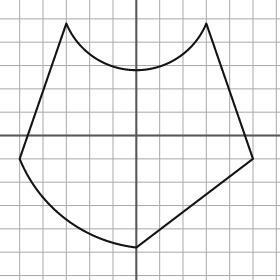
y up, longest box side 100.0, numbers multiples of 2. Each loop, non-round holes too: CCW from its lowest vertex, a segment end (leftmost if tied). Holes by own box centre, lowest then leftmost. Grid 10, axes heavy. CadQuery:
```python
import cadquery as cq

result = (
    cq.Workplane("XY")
    .moveTo(0.0, -48.0)
    .lineTo(50.0, -10.0)
    .lineTo(30.0, 48.0)
    .threePointArc((0.0, 28.0), (-30.0, 48.0))
    .lineTo(-50.0, -10.0)
    .threePointArc((-30.0, -36.0), (0.0, -48.0))
    .close()
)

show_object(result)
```